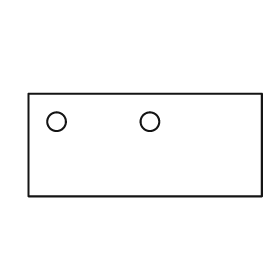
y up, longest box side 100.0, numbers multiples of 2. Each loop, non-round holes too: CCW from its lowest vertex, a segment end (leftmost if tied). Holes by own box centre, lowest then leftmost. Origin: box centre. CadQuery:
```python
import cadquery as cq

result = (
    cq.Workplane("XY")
    .moveTo(-50.0, -22.0)
    .lineTo(50.0, -22.0)
    .lineTo(50.0, 22.0)
    .lineTo(-50.0, 22.0)
    .close()
    .moveTo(-38.0, 10.0)
    .circle(4.0)
    .moveTo(2.0, 10.0)
    .circle(4.0)
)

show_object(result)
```